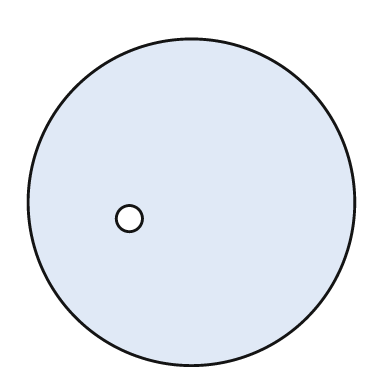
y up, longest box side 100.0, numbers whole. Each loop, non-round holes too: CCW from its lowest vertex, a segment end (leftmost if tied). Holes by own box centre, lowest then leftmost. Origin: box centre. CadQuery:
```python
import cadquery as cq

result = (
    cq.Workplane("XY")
    .moveTo(0.0, 0.0)
    .circle(50.0)
    .moveTo(-19.0, -5.0)
    .circle(4.0)
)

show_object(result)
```